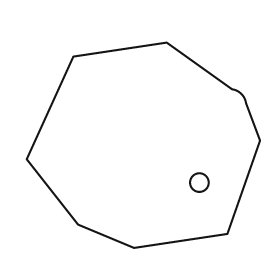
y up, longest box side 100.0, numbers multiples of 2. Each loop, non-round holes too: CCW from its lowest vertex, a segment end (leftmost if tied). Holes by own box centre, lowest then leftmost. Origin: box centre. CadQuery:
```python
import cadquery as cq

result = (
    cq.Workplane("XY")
    .moveTo(-4.0, -44.0)
    .lineTo(36.0, -38.0)
    .lineTo(50.0, 2.0)
    .lineTo(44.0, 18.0)
    .threePointArc((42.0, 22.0), (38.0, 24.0))
    .lineTo(10.0, 44.0)
    .lineTo(-30.0, 38.0)
    .lineTo(-50.0, -6.0)
    .lineTo(-28.0, -34.0)
    .close()
    .moveTo(24.0, -16.0)
    .circle(4.0)
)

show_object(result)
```